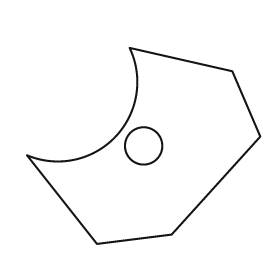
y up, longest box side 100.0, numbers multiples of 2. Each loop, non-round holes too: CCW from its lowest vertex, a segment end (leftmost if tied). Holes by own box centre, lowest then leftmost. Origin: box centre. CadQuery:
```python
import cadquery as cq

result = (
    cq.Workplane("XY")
    .moveTo(-20.0, -42.0)
    .lineTo(12.0, -38.0)
    .lineTo(50.0, 4.0)
    .lineTo(38.0, 32.0)
    .lineTo(-6.0, 42.0)
    .threePointArc((-12.0, 4.0), (-50.0, -4.0))
    .close()
    .moveTo(0.0, 0.0)
    .circle(8.0)
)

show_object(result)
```